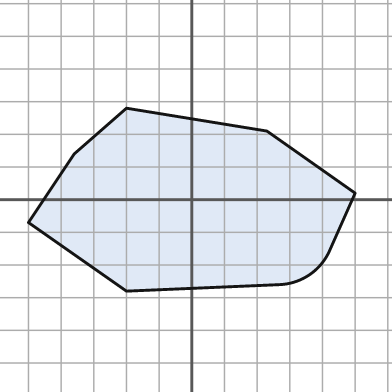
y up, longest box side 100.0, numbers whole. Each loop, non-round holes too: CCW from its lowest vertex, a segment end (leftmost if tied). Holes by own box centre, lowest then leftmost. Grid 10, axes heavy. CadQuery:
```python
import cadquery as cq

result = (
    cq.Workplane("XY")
    .moveTo(-20.0, -28.0)
    .lineTo(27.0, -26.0)
    .threePointArc((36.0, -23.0), (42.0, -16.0))
    .lineTo(50.0, 2.0)
    .lineTo(23.0, 21.0)
    .lineTo(-20.0, 28.0)
    .lineTo(-36.0, 14.0)
    .lineTo(-50.0, -7.0)
    .close()
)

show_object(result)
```